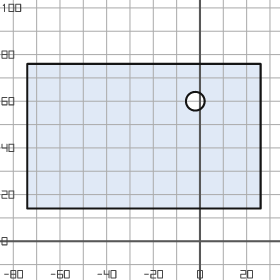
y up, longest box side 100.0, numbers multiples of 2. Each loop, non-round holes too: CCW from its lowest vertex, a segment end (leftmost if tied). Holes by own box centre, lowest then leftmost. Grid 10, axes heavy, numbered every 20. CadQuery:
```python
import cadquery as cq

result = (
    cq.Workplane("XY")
    .moveTo(-74.0, 14.0)
    .lineTo(26.0, 14.0)
    .lineTo(26.0, 76.0)
    .lineTo(-74.0, 76.0)
    .close()
    .moveTo(-2.0, 60.0)
    .circle(4.0)
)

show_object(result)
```